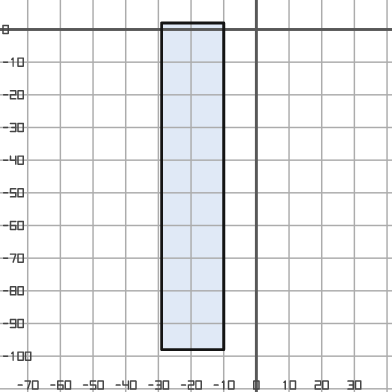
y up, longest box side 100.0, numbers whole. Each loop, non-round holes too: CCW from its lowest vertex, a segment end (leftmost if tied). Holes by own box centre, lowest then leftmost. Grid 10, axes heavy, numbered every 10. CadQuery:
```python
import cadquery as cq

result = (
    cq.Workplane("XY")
    .moveTo(-29.0, -98.0)
    .lineTo(-10.0, -98.0)
    .lineTo(-10.0, 2.0)
    .lineTo(-29.0, 2.0)
    .close()
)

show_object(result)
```